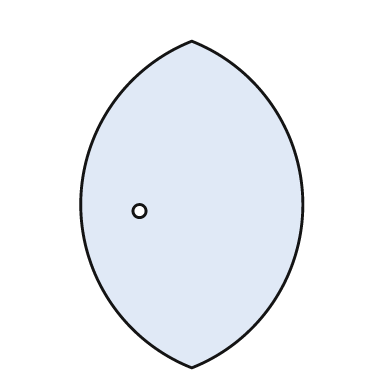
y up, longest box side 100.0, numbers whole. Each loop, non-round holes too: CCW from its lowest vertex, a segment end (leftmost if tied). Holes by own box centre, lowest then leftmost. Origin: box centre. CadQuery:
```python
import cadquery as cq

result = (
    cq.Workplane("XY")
    .moveTo(0.0, -50.0)
    .threePointArc((34.0, 0.0), (0.0, 50.0))
    .threePointArc((-34.0, 0.0), (0.0, -50.0))
    .close()
    .moveTo(-16.0, -2.0)
    .circle(2.0)
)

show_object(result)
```